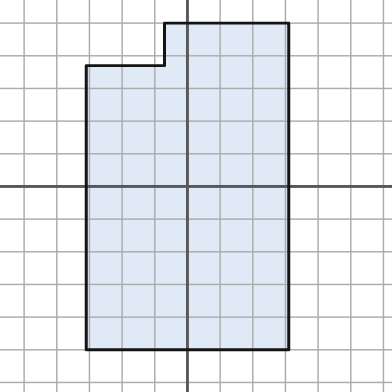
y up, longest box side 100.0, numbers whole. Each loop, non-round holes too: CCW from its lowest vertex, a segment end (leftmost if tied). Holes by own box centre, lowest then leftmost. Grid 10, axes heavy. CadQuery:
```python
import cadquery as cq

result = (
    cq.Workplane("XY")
    .moveTo(-31.0, -50.0)
    .lineTo(31.0, -50.0)
    .lineTo(31.0, 50.0)
    .lineTo(-7.0, 50.0)
    .lineTo(-7.0, 37.0)
    .lineTo(-31.0, 37.0)
    .close()
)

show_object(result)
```